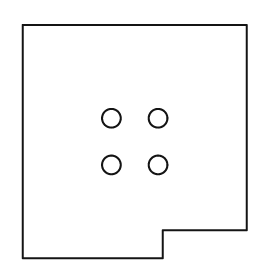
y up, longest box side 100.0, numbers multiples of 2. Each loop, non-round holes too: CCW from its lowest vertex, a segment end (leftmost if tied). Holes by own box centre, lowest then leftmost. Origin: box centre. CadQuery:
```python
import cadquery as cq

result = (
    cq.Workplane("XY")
    .moveTo(-48.0, -50.0)
    .lineTo(12.0, -50.0)
    .lineTo(12.0, -38.0)
    .lineTo(48.0, -38.0)
    .lineTo(48.0, 50.0)
    .lineTo(-48.0, 50.0)
    .close()
    .moveTo(-10.0, -10.0)
    .circle(4.0)
    .moveTo(10.0, -10.0)
    .circle(4.0)
    .moveTo(-10.0, 10.0)
    .circle(4.0)
    .moveTo(10.0, 10.0)
    .circle(4.0)
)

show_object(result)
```